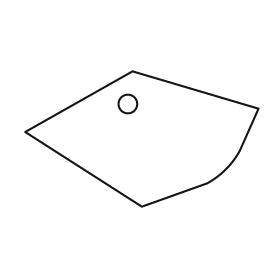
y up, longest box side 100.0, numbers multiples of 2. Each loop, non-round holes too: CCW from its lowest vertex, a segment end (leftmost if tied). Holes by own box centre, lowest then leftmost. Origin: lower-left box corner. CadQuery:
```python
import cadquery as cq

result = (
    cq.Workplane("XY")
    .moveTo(50.0, 0.0)
    .lineTo(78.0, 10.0)
    .threePointArc((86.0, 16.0), (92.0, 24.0))
    .lineTo(100.0, 42.0)
    .lineTo(46.0, 58.0)
    .lineTo(0.0, 32.0)
    .close()
    .moveTo(44.0, 44.0)
    .circle(4.0)
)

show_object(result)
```